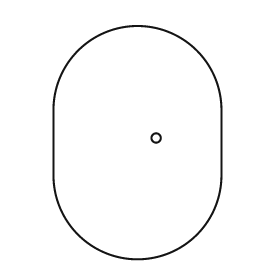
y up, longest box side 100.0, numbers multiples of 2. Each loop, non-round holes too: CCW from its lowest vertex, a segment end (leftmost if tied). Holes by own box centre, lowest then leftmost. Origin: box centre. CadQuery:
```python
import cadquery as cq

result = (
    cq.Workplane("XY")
    .moveTo(-36.0, -14.0)
    .threePointArc((0.0, -50.0), (36.0, -14.0))
    .lineTo(36.0, 14.0)
    .threePointArc((0.0, 50.0), (-36.0, 14.0))
    .close()
    .moveTo(8.0, 2.0)
    .circle(2.0)
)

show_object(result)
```